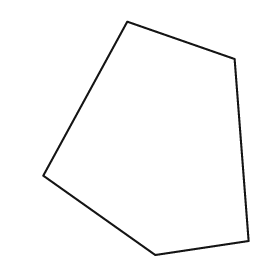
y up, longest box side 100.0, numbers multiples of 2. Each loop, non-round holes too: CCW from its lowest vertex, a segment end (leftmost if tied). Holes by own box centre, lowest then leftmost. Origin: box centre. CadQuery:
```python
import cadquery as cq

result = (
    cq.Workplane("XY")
    .moveTo(4.0, -50.0)
    .lineTo(44.0, -44.0)
    .lineTo(38.0, 34.0)
    .lineTo(-8.0, 50.0)
    .lineTo(-44.0, -16.0)
    .close()
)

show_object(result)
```